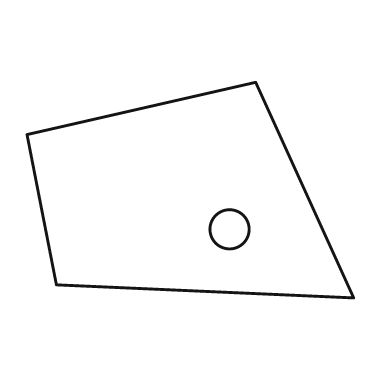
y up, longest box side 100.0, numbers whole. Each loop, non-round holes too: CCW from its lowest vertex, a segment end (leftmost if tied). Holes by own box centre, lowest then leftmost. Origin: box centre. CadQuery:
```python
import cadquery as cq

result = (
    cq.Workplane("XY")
    .moveTo(50.0, -33.0)
    .lineTo(20.0, 33.0)
    .lineTo(-50.0, 17.0)
    .lineTo(-41.0, -29.0)
    .close()
    .moveTo(12.0, -12.0)
    .circle(6.0)
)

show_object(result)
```